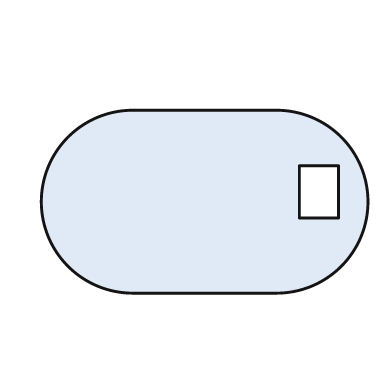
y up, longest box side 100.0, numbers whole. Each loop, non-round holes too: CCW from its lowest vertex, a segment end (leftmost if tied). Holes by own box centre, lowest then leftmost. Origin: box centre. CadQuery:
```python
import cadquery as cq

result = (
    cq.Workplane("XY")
    .moveTo(-22.0, -28.0)
    .lineTo(22.0, -28.0)
    .threePointArc((50.0, 0.0), (22.0, 28.0))
    .lineTo(-22.0, 28.0)
    .threePointArc((-50.0, 0.0), (-22.0, -28.0))
    .close()
    .moveTo(29.0, -5.0)
    .lineTo(41.0, -5.0)
    .lineTo(41.0, 11.0)
    .lineTo(29.0, 11.0)
    .close()
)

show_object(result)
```